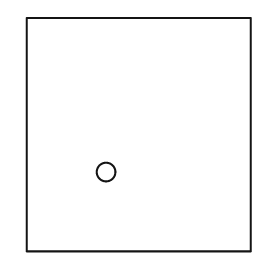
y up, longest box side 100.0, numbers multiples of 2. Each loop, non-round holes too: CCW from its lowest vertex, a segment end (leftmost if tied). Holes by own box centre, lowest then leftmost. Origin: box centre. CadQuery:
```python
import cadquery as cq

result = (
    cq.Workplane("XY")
    .moveTo(-48.0, -50.0)
    .lineTo(48.0, -50.0)
    .lineTo(48.0, 50.0)
    .lineTo(-48.0, 50.0)
    .close()
    .moveTo(-14.0, -16.0)
    .circle(4.0)
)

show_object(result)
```